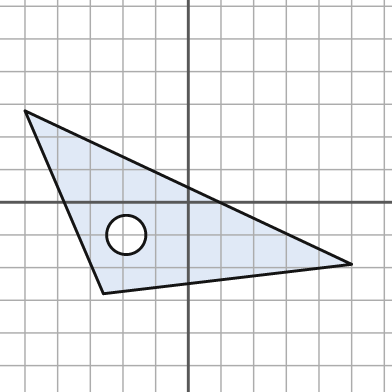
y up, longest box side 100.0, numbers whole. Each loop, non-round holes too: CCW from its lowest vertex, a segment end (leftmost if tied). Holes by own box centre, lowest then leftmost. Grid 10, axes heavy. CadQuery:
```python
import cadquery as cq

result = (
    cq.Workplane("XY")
    .moveTo(-26.0, -28.0)
    .lineTo(50.0, -19.0)
    .lineTo(-50.0, 28.0)
    .close()
    .moveTo(-19.0, -10.0)
    .circle(6.0)
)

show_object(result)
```